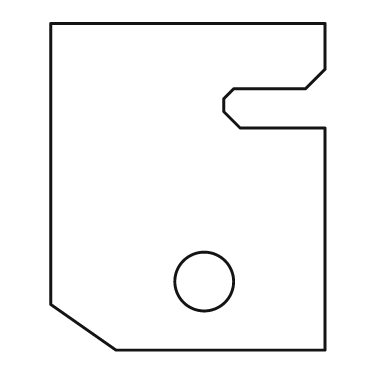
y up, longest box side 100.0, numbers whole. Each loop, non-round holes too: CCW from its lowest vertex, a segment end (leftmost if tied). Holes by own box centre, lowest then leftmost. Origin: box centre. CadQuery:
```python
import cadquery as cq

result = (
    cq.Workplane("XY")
    .moveTo(-22.0, -50.0)
    .lineTo(42.0, -50.0)
    .lineTo(42.0, 18.0)
    .lineTo(16.0, 18.0)
    .lineTo(11.0, 23.0)
    .lineTo(11.0, 27.0)
    .lineTo(14.0, 30.0)
    .lineTo(36.0, 30.0)
    .lineTo(42.0, 36.0)
    .lineTo(42.0, 50.0)
    .lineTo(-42.0, 50.0)
    .lineTo(-42.0, -36.0)
    .close()
    .moveTo(5.0, -29.0)
    .circle(9.0)
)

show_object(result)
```